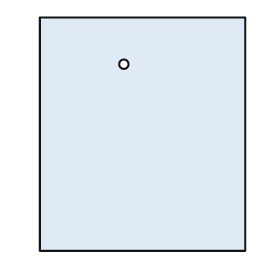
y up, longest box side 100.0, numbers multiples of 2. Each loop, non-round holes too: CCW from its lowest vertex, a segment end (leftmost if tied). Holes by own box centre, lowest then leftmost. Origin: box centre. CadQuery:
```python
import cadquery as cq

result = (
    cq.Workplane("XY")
    .moveTo(-44.0, -50.0)
    .lineTo(44.0, -50.0)
    .lineTo(44.0, 50.0)
    .lineTo(-44.0, 50.0)
    .close()
    .moveTo(-8.0, 30.0)
    .circle(2.0)
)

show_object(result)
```